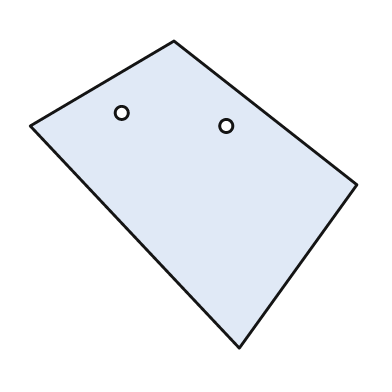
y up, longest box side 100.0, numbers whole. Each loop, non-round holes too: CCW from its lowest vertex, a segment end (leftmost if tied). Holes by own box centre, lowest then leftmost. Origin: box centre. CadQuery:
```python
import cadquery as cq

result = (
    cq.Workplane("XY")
    .moveTo(14.0, -47.0)
    .lineTo(50.0, 3.0)
    .lineTo(-6.0, 47.0)
    .lineTo(-50.0, 21.0)
    .close()
    .moveTo(10.0, 21.0)
    .circle(2.0)
    .moveTo(-22.0, 25.0)
    .circle(2.0)
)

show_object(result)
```